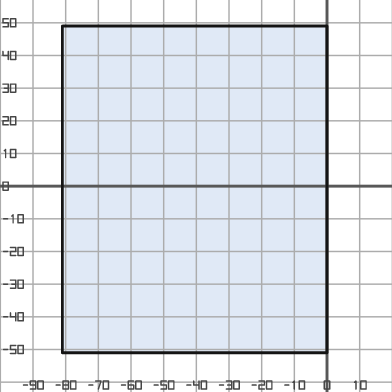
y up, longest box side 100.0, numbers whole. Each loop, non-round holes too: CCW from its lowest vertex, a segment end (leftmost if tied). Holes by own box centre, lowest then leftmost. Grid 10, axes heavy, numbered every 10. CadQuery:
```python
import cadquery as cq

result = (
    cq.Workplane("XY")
    .moveTo(-81.0, -51.0)
    .lineTo(0.0, -51.0)
    .lineTo(0.0, 49.0)
    .lineTo(-81.0, 49.0)
    .close()
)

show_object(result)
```